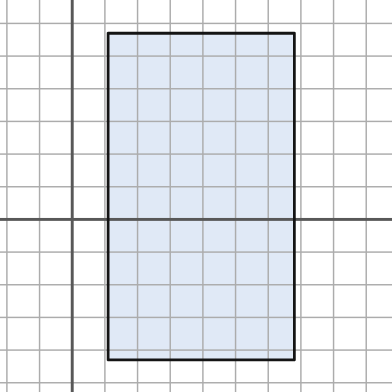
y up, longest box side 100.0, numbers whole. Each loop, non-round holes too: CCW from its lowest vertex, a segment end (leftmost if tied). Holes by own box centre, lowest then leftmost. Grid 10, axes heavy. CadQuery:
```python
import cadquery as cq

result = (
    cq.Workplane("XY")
    .moveTo(11.0, -43.0)
    .lineTo(68.0, -43.0)
    .lineTo(68.0, 57.0)
    .lineTo(11.0, 57.0)
    .close()
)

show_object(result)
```